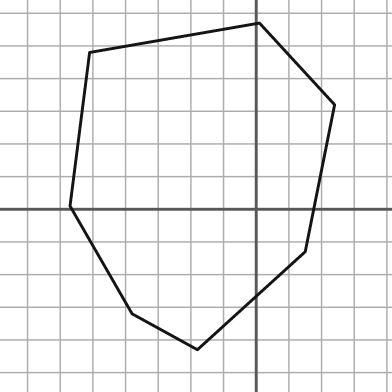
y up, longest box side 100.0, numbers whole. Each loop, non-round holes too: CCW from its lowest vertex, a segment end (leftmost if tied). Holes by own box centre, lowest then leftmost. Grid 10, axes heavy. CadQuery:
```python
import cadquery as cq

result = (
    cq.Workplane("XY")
    .moveTo(-18.0, -43.0)
    .lineTo(15.0, -13.0)
    .lineTo(24.0, 32.0)
    .lineTo(1.0, 57.0)
    .lineTo(-51.0, 48.0)
    .lineTo(-57.0, 1.0)
    .lineTo(-38.0, -32.0)
    .close()
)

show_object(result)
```